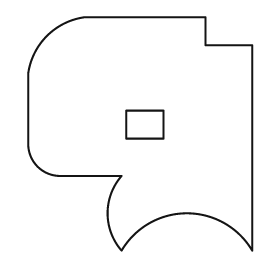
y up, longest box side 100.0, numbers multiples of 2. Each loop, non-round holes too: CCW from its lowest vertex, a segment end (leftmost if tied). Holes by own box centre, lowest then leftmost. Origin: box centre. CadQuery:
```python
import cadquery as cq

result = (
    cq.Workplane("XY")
    .moveTo(-8.0, -50.0)
    .threePointArc((20.0, -34.0), (48.0, -50.0))
    .lineTo(48.0, 38.0)
    .lineTo(28.0, 38.0)
    .lineTo(28.0, 50.0)
    .lineTo(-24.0, 50.0)
    .threePointArc((-40.0, 42.0), (-48.0, 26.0))
    .lineTo(-48.0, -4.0)
    .threePointArc((-44.0, -14.0), (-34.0, -18.0))
    .lineTo(-8.0, -18.0)
    .threePointArc((-14.0, -34.0), (-8.0, -50.0))
    .close()
    .moveTo(-6.0, -2.0)
    .lineTo(10.0, -2.0)
    .lineTo(10.0, 10.0)
    .lineTo(-6.0, 10.0)
    .close()
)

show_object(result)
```